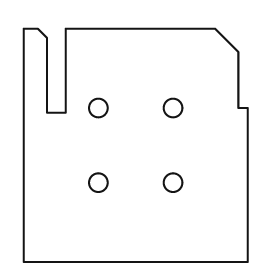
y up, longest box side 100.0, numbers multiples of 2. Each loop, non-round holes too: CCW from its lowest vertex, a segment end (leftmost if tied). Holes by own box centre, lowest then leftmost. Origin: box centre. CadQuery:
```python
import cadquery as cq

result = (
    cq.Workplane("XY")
    .moveTo(-48.0, -50.0)
    .lineTo(48.0, -50.0)
    .lineTo(48.0, 16.0)
    .lineTo(44.0, 16.0)
    .lineTo(44.0, 40.0)
    .lineTo(34.0, 50.0)
    .lineTo(-30.0, 50.0)
    .lineTo(-30.0, 14.0)
    .lineTo(-38.0, 14.0)
    .lineTo(-38.0, 46.0)
    .lineTo(-42.0, 50.0)
    .lineTo(-48.0, 50.0)
    .close()
    .moveTo(-16.0, -16.0)
    .circle(4.0)
    .moveTo(16.0, -16.0)
    .circle(4.0)
    .moveTo(-16.0, 16.0)
    .circle(4.0)
    .moveTo(16.0, 16.0)
    .circle(4.0)
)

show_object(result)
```